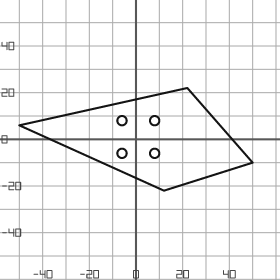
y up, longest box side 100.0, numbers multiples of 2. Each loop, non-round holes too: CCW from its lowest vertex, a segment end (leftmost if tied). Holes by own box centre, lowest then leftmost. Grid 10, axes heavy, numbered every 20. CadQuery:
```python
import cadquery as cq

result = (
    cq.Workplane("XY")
    .moveTo(12.0, -22.0)
    .lineTo(50.0, -10.0)
    .lineTo(22.0, 22.0)
    .lineTo(-50.0, 6.0)
    .close()
    .moveTo(-6.0, -6.0)
    .circle(2.0)
    .moveTo(8.0, -6.0)
    .circle(2.0)
    .moveTo(-6.0, 8.0)
    .circle(2.0)
    .moveTo(8.0, 8.0)
    .circle(2.0)
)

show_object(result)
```